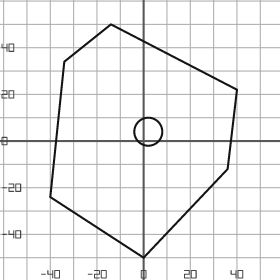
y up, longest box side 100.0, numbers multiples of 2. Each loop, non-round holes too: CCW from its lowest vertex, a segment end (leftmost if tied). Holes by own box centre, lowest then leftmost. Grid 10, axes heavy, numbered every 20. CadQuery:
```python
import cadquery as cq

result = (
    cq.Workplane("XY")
    .moveTo(0.0, -50.0)
    .lineTo(36.0, -12.0)
    .lineTo(40.0, 22.0)
    .lineTo(-14.0, 50.0)
    .lineTo(-34.0, 34.0)
    .lineTo(-40.0, -24.0)
    .close()
    .moveTo(2.0, 4.0)
    .circle(6.0)
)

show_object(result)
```